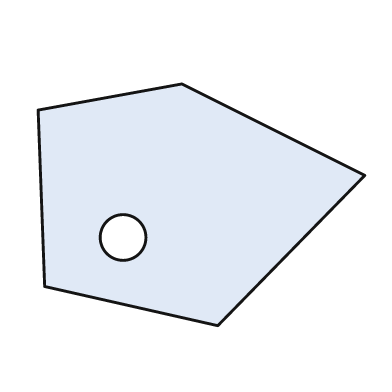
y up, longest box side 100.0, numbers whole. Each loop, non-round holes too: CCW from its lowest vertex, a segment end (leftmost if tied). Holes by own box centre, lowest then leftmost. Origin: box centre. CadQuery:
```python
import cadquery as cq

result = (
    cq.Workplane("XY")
    .moveTo(5.0, -37.0)
    .lineTo(50.0, 9.0)
    .lineTo(-6.0, 37.0)
    .lineTo(-50.0, 29.0)
    .lineTo(-48.0, -25.0)
    .close()
    .moveTo(-24.0, -10.0)
    .circle(7.0)
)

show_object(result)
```